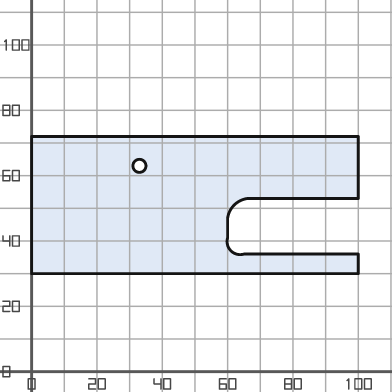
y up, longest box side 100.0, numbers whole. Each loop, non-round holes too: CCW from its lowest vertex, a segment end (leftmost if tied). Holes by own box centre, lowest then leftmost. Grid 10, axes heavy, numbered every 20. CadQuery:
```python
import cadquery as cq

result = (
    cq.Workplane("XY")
    .moveTo(0.0, 30.0)
    .lineTo(100.0, 30.0)
    .lineTo(100.0, 36.0)
    .lineTo(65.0, 36.0)
    .threePointArc((61.0, 37.0), (60.0, 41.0))
    .lineTo(60.0, 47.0)
    .threePointArc((62.0, 51.0), (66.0, 53.0))
    .lineTo(100.0, 53.0)
    .lineTo(100.0, 72.0)
    .lineTo(0.0, 72.0)
    .close()
    .moveTo(33.0, 63.0)
    .circle(2.0)
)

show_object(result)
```